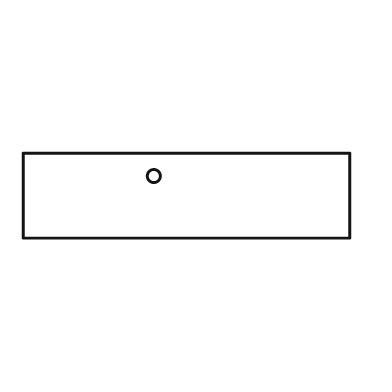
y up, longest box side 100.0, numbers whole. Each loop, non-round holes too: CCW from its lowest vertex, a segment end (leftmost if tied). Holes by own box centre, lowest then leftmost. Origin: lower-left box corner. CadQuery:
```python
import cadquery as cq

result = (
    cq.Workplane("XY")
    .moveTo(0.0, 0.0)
    .lineTo(100.0, 0.0)
    .lineTo(100.0, 26.0)
    .lineTo(0.0, 26.0)
    .close()
    .moveTo(40.0, 19.0)
    .circle(2.0)
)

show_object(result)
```